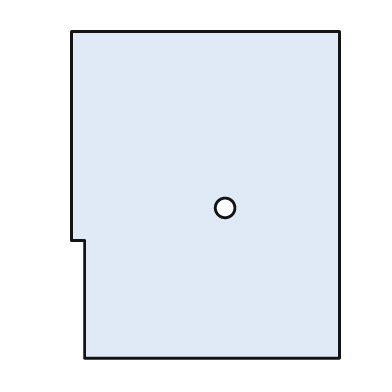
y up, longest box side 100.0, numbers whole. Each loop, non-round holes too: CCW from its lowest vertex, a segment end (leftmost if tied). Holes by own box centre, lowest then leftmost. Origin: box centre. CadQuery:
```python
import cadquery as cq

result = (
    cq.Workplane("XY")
    .moveTo(-37.0, -50.0)
    .lineTo(41.0, -50.0)
    .lineTo(41.0, 50.0)
    .lineTo(-41.0, 50.0)
    .lineTo(-41.0, -14.0)
    .lineTo(-37.0, -14.0)
    .close()
    .moveTo(6.0, -4.0)
    .circle(3.0)
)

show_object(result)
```